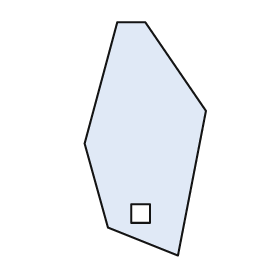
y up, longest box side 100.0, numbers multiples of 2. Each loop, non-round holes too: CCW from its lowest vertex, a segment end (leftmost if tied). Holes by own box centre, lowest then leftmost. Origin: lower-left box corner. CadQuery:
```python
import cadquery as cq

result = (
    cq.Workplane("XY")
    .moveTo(40.0, 0.0)
    .lineTo(52.0, 62.0)
    .lineTo(26.0, 100.0)
    .lineTo(14.0, 100.0)
    .lineTo(0.0, 48.0)
    .lineTo(10.0, 12.0)
    .close()
    .moveTo(20.0, 14.0)
    .lineTo(28.0, 14.0)
    .lineTo(28.0, 22.0)
    .lineTo(20.0, 22.0)
    .close()
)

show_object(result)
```